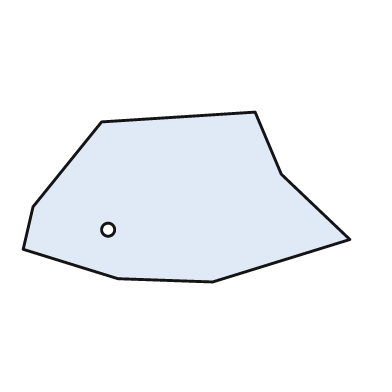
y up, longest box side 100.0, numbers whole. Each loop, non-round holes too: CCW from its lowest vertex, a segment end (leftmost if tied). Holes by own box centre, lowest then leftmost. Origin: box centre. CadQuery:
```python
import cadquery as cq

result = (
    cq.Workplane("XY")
    .moveTo(8.0, -26.0)
    .lineTo(50.0, -13.0)
    .lineTo(29.0, 7.0)
    .lineTo(21.0, 26.0)
    .lineTo(-26.0, 23.0)
    .lineTo(-47.0, -3.0)
    .lineTo(-50.0, -16.0)
    .lineTo(-21.0, -25.0)
    .close()
    .moveTo(-24.0, -10.0)
    .circle(2.0)
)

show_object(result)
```